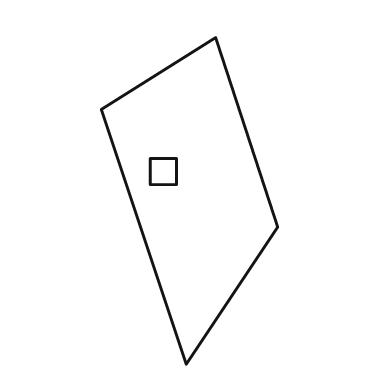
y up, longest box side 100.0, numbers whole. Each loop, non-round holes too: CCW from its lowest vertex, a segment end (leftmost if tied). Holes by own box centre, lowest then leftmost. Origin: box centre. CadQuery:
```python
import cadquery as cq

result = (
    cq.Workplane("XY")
    .moveTo(-1.0, -50.0)
    .lineTo(27.0, -8.0)
    .lineTo(8.0, 50.0)
    .lineTo(-27.0, 28.0)
    .close()
    .moveTo(-12.0, 5.0)
    .lineTo(-4.0, 5.0)
    .lineTo(-4.0, 13.0)
    .lineTo(-12.0, 13.0)
    .close()
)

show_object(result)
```